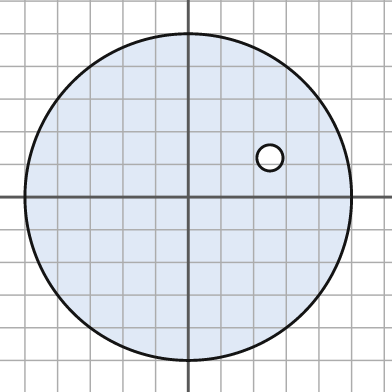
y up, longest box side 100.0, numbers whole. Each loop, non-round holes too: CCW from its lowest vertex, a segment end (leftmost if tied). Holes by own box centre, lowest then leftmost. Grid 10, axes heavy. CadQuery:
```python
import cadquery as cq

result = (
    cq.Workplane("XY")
    .moveTo(0.0, 0.0)
    .circle(50.0)
    .moveTo(25.0, 12.0)
    .circle(4.0)
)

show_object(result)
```